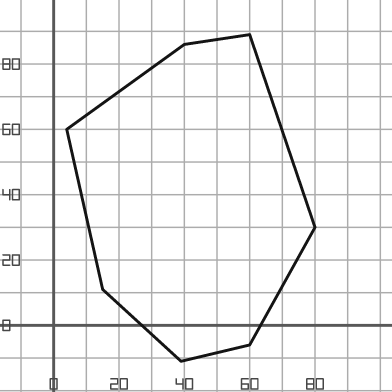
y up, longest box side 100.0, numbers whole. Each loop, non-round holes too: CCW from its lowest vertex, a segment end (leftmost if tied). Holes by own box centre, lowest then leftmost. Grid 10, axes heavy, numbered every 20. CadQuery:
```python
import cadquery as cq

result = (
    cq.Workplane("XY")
    .moveTo(39.0, -11.0)
    .lineTo(60.0, -6.0)
    .lineTo(80.0, 30.0)
    .lineTo(60.0, 89.0)
    .lineTo(40.0, 86.0)
    .lineTo(4.0, 60.0)
    .lineTo(15.0, 11.0)
    .close()
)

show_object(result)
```